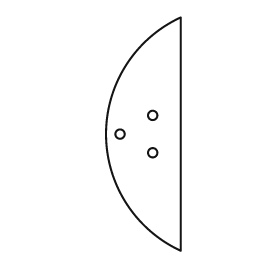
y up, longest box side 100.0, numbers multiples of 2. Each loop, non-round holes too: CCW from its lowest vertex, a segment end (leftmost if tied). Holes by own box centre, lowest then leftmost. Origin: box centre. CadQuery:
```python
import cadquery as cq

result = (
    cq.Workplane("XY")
    .moveTo(16.0, -50.0)
    .lineTo(16.0, 50.0)
    .threePointArc((-16.0, 0.0), (16.0, -50.0))
    .close()
    .moveTo(4.0, -8.0)
    .circle(2.0)
    .moveTo(-10.0, 0.0)
    .circle(2.0)
    .moveTo(4.0, 8.0)
    .circle(2.0)
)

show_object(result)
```